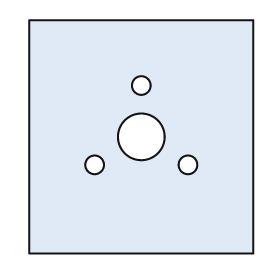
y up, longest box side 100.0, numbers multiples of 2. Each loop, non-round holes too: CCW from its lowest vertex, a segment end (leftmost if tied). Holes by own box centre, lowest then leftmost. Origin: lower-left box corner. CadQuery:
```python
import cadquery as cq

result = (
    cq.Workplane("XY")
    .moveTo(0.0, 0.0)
    .lineTo(96.0, 0.0)
    .lineTo(96.0, 100.0)
    .lineTo(0.0, 100.0)
    .close()
    .moveTo(28.0, 38.0)
    .circle(4.0)
    .moveTo(68.0, 38.0)
    .circle(4.0)
    .moveTo(48.0, 50.0)
    .circle(10.0)
    .moveTo(48.0, 72.0)
    .circle(4.0)
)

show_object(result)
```